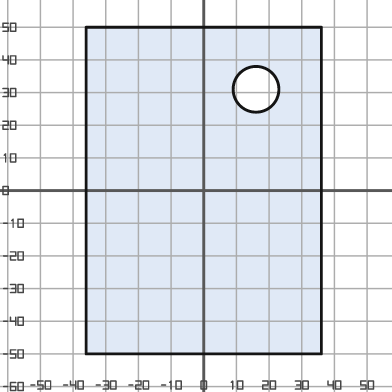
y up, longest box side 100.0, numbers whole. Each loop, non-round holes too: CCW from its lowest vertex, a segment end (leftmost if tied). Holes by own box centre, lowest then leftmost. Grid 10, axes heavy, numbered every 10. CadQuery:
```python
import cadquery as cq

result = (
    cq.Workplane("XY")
    .moveTo(-36.0, -50.0)
    .lineTo(36.0, -50.0)
    .lineTo(36.0, 50.0)
    .lineTo(-36.0, 50.0)
    .close()
    .moveTo(16.0, 31.0)
    .circle(7.0)
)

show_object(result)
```